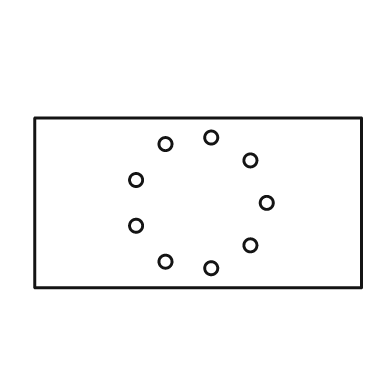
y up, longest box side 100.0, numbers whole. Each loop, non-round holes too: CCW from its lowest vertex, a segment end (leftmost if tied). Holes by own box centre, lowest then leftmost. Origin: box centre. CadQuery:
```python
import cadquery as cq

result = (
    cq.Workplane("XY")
    .moveTo(-50.0, -26.0)
    .lineTo(50.0, -26.0)
    .lineTo(50.0, 26.0)
    .lineTo(-50.0, 26.0)
    .close()
    .moveTo(4.0, -20.0)
    .circle(2.0)
    .moveTo(-10.0, -18.0)
    .circle(2.0)
    .moveTo(16.0, -13.0)
    .circle(2.0)
    .moveTo(-19.0, -7.0)
    .circle(2.0)
    .moveTo(21.0, 0.0)
    .circle(2.0)
    .moveTo(-19.0, 7.0)
    .circle(2.0)
    .moveTo(16.0, 13.0)
    .circle(2.0)
    .moveTo(-10.0, 18.0)
    .circle(2.0)
    .moveTo(4.0, 20.0)
    .circle(2.0)
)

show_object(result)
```